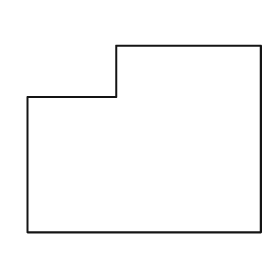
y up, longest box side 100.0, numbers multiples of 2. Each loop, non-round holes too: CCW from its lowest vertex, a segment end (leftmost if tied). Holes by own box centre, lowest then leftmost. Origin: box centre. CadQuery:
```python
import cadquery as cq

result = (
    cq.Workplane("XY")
    .moveTo(-50.0, -40.0)
    .lineTo(50.0, -40.0)
    .lineTo(50.0, 40.0)
    .lineTo(-12.0, 40.0)
    .lineTo(-12.0, 18.0)
    .lineTo(-50.0, 18.0)
    .close()
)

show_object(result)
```